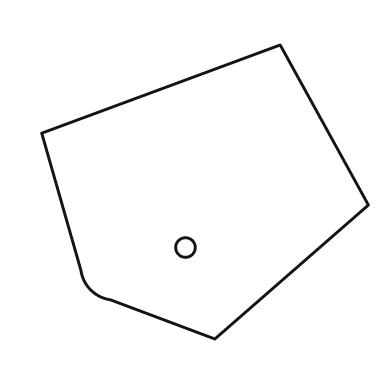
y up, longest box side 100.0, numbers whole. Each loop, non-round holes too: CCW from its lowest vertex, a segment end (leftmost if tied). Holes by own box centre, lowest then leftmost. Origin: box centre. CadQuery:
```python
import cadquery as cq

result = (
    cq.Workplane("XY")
    .moveTo(3.0, -45.0)
    .lineTo(50.0, -4.0)
    .lineTo(23.0, 45.0)
    .lineTo(-50.0, 18.0)
    .lineTo(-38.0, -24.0)
    .threePointArc((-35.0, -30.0), (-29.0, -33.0))
    .close()
    .moveTo(-6.0, -17.0)
    .circle(3.0)
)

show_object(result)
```